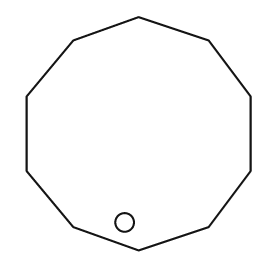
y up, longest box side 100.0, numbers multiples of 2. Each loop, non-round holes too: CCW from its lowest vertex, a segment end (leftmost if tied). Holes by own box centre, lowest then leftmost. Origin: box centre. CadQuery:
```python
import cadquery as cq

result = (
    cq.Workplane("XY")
    .moveTo(0.0, -50.0)
    .lineTo(30.0, -40.0)
    .lineTo(48.0, -16.0)
    .lineTo(48.0, 16.0)
    .lineTo(30.0, 40.0)
    .lineTo(0.0, 50.0)
    .lineTo(-28.0, 40.0)
    .lineTo(-48.0, 16.0)
    .lineTo(-48.0, -16.0)
    .lineTo(-28.0, -40.0)
    .close()
    .moveTo(-6.0, -38.0)
    .circle(4.0)
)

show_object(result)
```